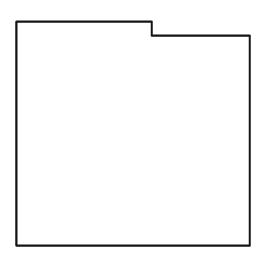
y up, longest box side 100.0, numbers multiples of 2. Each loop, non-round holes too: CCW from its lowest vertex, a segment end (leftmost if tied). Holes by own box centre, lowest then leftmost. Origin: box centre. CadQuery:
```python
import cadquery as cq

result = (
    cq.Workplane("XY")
    .moveTo(-50.0, -48.0)
    .lineTo(50.0, -48.0)
    .lineTo(50.0, 42.0)
    .lineTo(8.0, 42.0)
    .lineTo(8.0, 48.0)
    .lineTo(-50.0, 48.0)
    .close()
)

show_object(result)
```